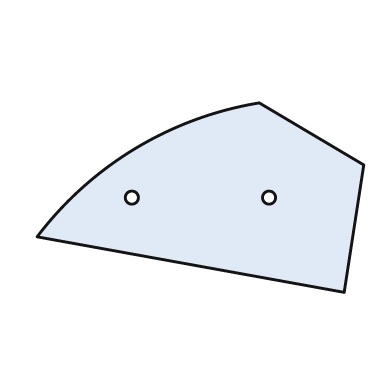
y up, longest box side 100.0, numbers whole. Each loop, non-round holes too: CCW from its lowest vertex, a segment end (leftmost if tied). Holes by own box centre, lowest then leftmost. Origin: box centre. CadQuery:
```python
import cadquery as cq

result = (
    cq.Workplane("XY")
    .moveTo(44.0, -29.0)
    .lineTo(50.0, 10.0)
    .lineTo(18.0, 29.0)
    .threePointArc((-20.0, 15.0), (-50.0, -12.0))
    .close()
    .moveTo(-21.0, 0.0)
    .circle(2.0)
    .moveTo(21.0, 0.0)
    .circle(2.0)
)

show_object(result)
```